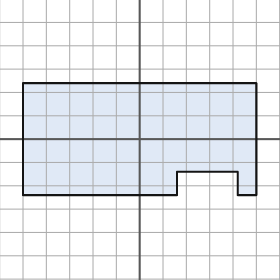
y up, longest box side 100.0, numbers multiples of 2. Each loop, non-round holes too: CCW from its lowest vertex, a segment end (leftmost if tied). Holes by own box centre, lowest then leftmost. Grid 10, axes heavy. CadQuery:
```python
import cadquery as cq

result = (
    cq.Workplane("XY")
    .moveTo(-50.0, -24.0)
    .lineTo(16.0, -24.0)
    .lineTo(16.0, -14.0)
    .lineTo(42.0, -14.0)
    .lineTo(42.0, -24.0)
    .lineTo(50.0, -24.0)
    .lineTo(50.0, 24.0)
    .lineTo(-50.0, 24.0)
    .close()
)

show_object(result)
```